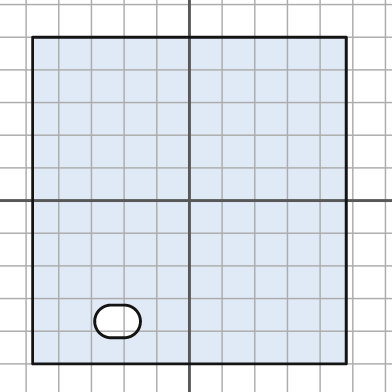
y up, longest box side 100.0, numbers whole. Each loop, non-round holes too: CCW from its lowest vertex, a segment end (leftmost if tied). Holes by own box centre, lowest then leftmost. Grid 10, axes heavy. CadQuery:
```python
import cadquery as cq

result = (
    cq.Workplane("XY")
    .moveTo(-48.0, -50.0)
    .lineTo(48.0, -50.0)
    .lineTo(48.0, 50.0)
    .lineTo(-48.0, 50.0)
    .close()
    .moveTo(-24.0, -42.0)
    .lineTo(-20.0, -42.0)
    .threePointArc((-15.0, -37.0), (-20.0, -32.0))
    .lineTo(-24.0, -32.0)
    .threePointArc((-29.0, -37.0), (-24.0, -42.0))
    .close()
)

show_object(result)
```